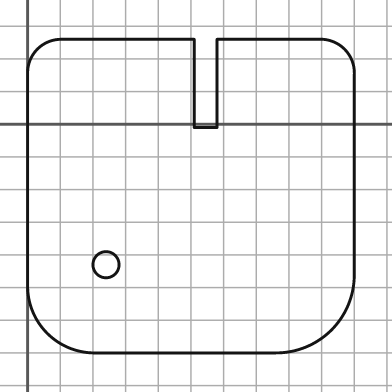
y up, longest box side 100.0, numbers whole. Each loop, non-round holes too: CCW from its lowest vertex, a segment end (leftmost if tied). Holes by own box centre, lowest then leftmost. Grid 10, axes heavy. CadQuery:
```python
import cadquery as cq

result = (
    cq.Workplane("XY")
    .moveTo(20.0, -70.0)
    .lineTo(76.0, -70.0)
    .threePointArc((93.0, -63.0), (100.0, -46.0))
    .lineTo(100.0, 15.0)
    .threePointArc((97.0, 23.0), (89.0, 26.0))
    .lineTo(58.0, 26.0)
    .lineTo(58.0, -1.0)
    .lineTo(51.0, -1.0)
    .lineTo(51.0, 26.0)
    .lineTo(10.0, 26.0)
    .threePointArc((3.0, 23.0), (0.0, 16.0))
    .lineTo(0.0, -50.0)
    .threePointArc((6.0, -64.0), (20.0, -70.0))
    .close()
    .moveTo(24.0, -43.0)
    .circle(4.0)
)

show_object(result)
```